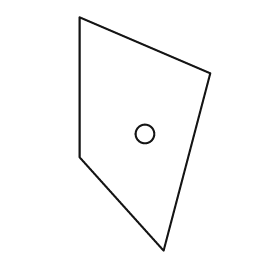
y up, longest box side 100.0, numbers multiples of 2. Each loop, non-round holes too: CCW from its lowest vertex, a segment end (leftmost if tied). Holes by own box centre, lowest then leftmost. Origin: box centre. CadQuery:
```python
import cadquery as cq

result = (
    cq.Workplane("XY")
    .moveTo(8.0, -50.0)
    .lineTo(28.0, 26.0)
    .lineTo(-28.0, 50.0)
    .lineTo(-28.0, -10.0)
    .close()
    .moveTo(0.0, 0.0)
    .circle(4.0)
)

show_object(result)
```